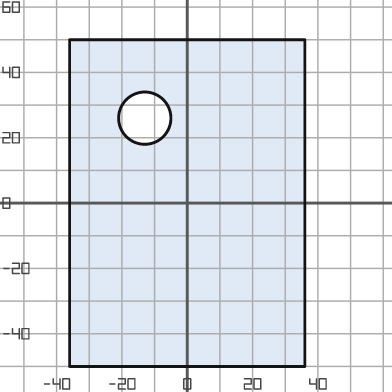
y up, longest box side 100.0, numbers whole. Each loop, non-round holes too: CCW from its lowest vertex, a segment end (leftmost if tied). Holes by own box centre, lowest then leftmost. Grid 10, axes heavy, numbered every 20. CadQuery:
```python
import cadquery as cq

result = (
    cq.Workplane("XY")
    .moveTo(-36.0, -50.0)
    .lineTo(36.0, -50.0)
    .lineTo(36.0, 50.0)
    .lineTo(-36.0, 50.0)
    .close()
    .moveTo(-13.0, 26.0)
    .circle(8.0)
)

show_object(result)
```